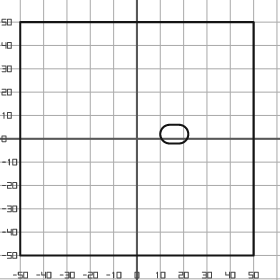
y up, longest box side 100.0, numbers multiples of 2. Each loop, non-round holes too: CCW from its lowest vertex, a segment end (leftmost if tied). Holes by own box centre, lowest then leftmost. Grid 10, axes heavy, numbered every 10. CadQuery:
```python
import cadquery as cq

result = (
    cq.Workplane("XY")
    .moveTo(-50.0, -50.0)
    .lineTo(50.0, -50.0)
    .lineTo(50.0, 50.0)
    .lineTo(-50.0, 50.0)
    .close()
    .moveTo(14.0, -2.0)
    .lineTo(18.0, -2.0)
    .threePointArc((22.0, 2.0), (18.0, 6.0))
    .lineTo(14.0, 6.0)
    .threePointArc((10.0, 2.0), (14.0, -2.0))
    .close()
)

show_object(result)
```